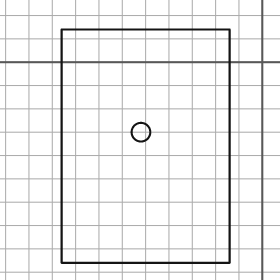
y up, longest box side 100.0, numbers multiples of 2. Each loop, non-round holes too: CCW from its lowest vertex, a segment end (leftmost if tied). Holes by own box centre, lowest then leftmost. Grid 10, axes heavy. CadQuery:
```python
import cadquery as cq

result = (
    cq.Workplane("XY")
    .moveTo(-86.0, -86.0)
    .lineTo(-14.0, -86.0)
    .lineTo(-14.0, 14.0)
    .lineTo(-86.0, 14.0)
    .close()
    .moveTo(-52.0, -30.0)
    .circle(4.0)
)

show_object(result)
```